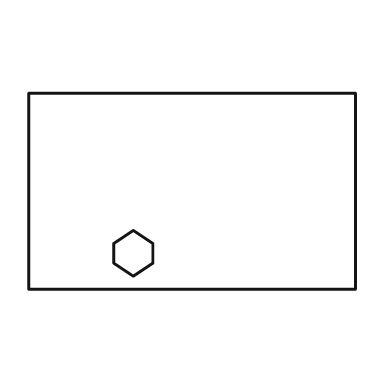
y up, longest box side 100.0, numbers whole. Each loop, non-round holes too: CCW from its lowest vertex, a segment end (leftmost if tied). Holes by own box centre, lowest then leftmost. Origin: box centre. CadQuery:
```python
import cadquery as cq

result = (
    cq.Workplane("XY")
    .moveTo(-50.0, -30.0)
    .lineTo(50.0, -30.0)
    .lineTo(50.0, 30.0)
    .lineTo(-50.0, 30.0)
    .close()
    .moveTo(-18.0, -26.0)
    .lineTo(-12.0, -22.0)
    .lineTo(-12.0, -16.0)
    .lineTo(-18.0, -12.0)
    .lineTo(-24.0, -16.0)
    .lineTo(-24.0, -22.0)
    .close()
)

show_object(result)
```